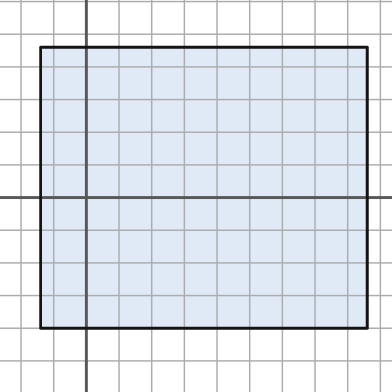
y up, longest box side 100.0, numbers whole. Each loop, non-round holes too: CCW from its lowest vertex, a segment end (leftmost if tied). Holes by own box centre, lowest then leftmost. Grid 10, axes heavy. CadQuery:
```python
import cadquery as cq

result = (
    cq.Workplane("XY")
    .moveTo(-14.0, -40.0)
    .lineTo(86.0, -40.0)
    .lineTo(86.0, 46.0)
    .lineTo(-14.0, 46.0)
    .close()
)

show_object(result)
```